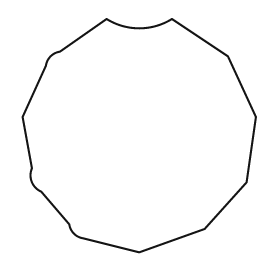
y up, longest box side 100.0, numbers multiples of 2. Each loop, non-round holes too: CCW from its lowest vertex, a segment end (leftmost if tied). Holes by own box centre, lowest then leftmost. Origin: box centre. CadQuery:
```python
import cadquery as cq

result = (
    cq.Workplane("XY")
    .moveTo(0.0, -50.0)
    .lineTo(28.0, -40.0)
    .lineTo(46.0, -20.0)
    .lineTo(50.0, 8.0)
    .lineTo(38.0, 34.0)
    .lineTo(14.0, 50.0)
    .threePointArc((0.0, 46.0), (-14.0, 50.0))
    .lineTo(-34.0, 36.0)
    .threePointArc((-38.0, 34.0), (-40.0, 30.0))
    .lineTo(-50.0, 8.0)
    .lineTo(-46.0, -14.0)
    .threePointArc((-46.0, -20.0), (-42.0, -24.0))
    .lineTo(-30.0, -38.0)
    .threePointArc((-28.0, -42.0), (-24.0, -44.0))
    .close()
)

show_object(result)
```